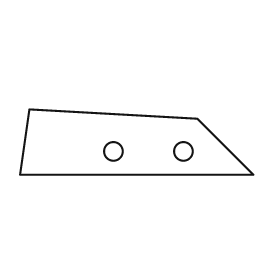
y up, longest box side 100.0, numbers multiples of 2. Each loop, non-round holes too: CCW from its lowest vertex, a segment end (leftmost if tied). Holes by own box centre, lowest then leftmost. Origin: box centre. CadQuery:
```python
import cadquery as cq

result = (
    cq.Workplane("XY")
    .moveTo(-50.0, -14.0)
    .lineTo(50.0, -14.0)
    .lineTo(26.0, 10.0)
    .lineTo(-46.0, 14.0)
    .close()
    .moveTo(-10.0, -4.0)
    .circle(4.0)
    .moveTo(20.0, -4.0)
    .circle(4.0)
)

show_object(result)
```